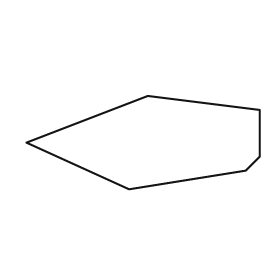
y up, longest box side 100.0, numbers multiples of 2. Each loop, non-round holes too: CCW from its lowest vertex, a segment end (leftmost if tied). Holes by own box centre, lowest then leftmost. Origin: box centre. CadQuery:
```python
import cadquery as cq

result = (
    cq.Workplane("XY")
    .moveTo(-6.0, -20.0)
    .lineTo(44.0, -12.0)
    .lineTo(50.0, -6.0)
    .lineTo(50.0, 14.0)
    .lineTo(2.0, 20.0)
    .lineTo(-50.0, 0.0)
    .close()
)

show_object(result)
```